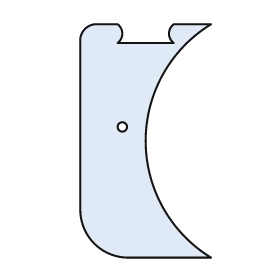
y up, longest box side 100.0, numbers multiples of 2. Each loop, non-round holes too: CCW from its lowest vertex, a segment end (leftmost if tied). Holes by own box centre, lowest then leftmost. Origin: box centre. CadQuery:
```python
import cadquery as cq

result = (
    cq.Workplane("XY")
    .moveTo(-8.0, -50.0)
    .lineTo(28.0, -50.0)
    .threePointArc((0.0, 0.0), (28.0, 50.0))
    .lineTo(12.0, 50.0)
    .threePointArc((10.0, 46.0), (12.0, 42.0))
    .lineTo(-12.0, 42.0)
    .threePointArc((-10.0, 46.0), (-12.0, 50.0))
    .lineTo(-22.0, 50.0)
    .threePointArc((-26.0, 48.0), (-28.0, 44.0))
    .lineTo(-28.0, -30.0)
    .threePointArc((-22.0, -44.0), (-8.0, -50.0))
    .close()
    .moveTo(-10.0, 6.0)
    .circle(2.0)
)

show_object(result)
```